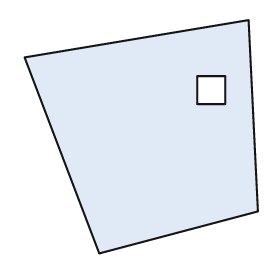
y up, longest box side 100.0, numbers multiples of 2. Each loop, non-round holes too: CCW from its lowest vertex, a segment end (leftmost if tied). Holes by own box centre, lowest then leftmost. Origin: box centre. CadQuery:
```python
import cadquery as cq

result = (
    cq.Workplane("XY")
    .moveTo(-18.0, -50.0)
    .lineTo(50.0, -32.0)
    .lineTo(46.0, 50.0)
    .lineTo(-50.0, 34.0)
    .close()
    .moveTo(24.0, 14.0)
    .lineTo(36.0, 14.0)
    .lineTo(36.0, 26.0)
    .lineTo(24.0, 26.0)
    .close()
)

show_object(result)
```